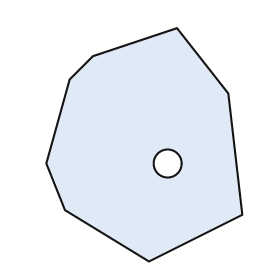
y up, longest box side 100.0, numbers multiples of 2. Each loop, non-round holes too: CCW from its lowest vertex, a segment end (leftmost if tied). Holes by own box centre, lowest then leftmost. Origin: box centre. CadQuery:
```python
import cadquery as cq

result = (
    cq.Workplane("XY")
    .moveTo(2.0, -50.0)
    .lineTo(42.0, -30.0)
    .lineTo(36.0, 22.0)
    .lineTo(14.0, 50.0)
    .lineTo(-22.0, 38.0)
    .lineTo(-32.0, 28.0)
    .lineTo(-42.0, -8.0)
    .lineTo(-34.0, -28.0)
    .close()
    .moveTo(10.0, -8.0)
    .circle(6.0)
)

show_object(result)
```